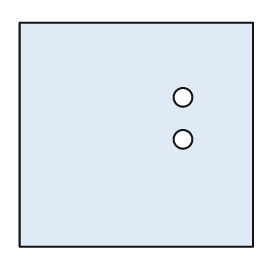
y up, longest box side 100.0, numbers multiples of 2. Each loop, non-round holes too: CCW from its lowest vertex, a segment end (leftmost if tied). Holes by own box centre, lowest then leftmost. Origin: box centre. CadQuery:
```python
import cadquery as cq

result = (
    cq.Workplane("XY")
    .moveTo(-50.0, -48.0)
    .lineTo(50.0, -48.0)
    .lineTo(50.0, 48.0)
    .lineTo(-50.0, 48.0)
    .close()
    .moveTo(20.0, -2.0)
    .circle(4.0)
    .moveTo(20.0, 16.0)
    .circle(4.0)
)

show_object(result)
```